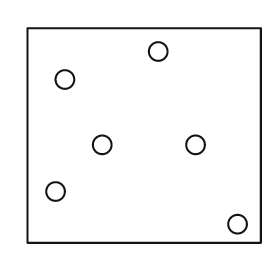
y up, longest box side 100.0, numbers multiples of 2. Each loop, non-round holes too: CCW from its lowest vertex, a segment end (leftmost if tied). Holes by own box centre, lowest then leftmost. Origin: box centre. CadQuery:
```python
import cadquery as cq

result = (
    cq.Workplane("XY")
    .moveTo(-50.0, -46.0)
    .lineTo(50.0, -46.0)
    .lineTo(50.0, 46.0)
    .lineTo(-50.0, 46.0)
    .close()
    .moveTo(40.0, -38.0)
    .circle(4.0)
    .moveTo(-38.0, -24.0)
    .circle(4.0)
    .moveTo(-18.0, -4.0)
    .circle(4.0)
    .moveTo(22.0, -4.0)
    .circle(4.0)
    .moveTo(-34.0, 24.0)
    .circle(4.0)
    .moveTo(6.0, 36.0)
    .circle(4.0)
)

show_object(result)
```